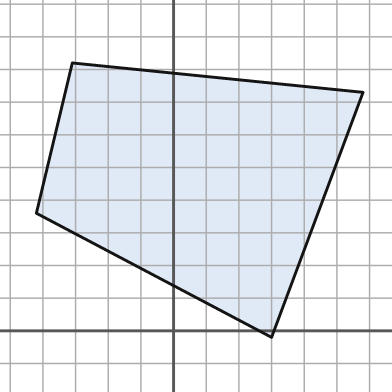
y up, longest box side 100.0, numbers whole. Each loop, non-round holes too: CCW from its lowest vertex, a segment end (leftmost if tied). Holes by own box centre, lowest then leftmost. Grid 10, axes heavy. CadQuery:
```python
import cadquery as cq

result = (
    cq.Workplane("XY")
    .moveTo(30.0, -2.0)
    .lineTo(58.0, 73.0)
    .lineTo(-31.0, 82.0)
    .lineTo(-42.0, 36.0)
    .close()
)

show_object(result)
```